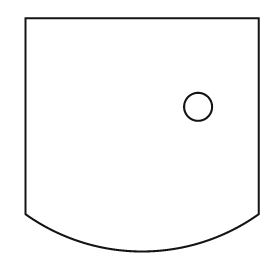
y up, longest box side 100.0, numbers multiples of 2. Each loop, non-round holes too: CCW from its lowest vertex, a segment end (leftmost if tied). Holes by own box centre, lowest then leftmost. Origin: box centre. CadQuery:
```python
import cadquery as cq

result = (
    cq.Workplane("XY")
    .moveTo(-50.0, -34.0)
    .threePointArc((0.0, -50.0), (50.0, -34.0))
    .lineTo(50.0, 50.0)
    .lineTo(-50.0, 50.0)
    .close()
    .moveTo(24.0, 12.0)
    .circle(6.0)
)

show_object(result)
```